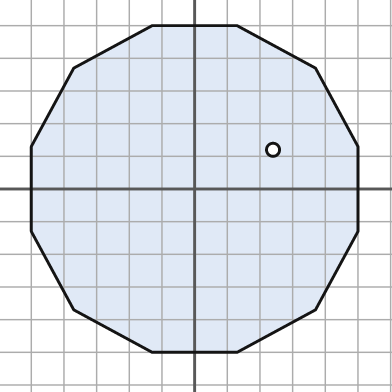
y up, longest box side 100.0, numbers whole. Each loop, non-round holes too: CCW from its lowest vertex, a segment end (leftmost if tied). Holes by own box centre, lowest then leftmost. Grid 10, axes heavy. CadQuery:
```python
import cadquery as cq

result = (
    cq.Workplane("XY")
    .moveTo(-13.0, -50.0)
    .lineTo(13.0, -50.0)
    .lineTo(37.0, -37.0)
    .lineTo(50.0, -13.0)
    .lineTo(50.0, 13.0)
    .lineTo(37.0, 37.0)
    .lineTo(13.0, 50.0)
    .lineTo(-13.0, 50.0)
    .lineTo(-37.0, 37.0)
    .lineTo(-50.0, 13.0)
    .lineTo(-50.0, -13.0)
    .lineTo(-37.0, -37.0)
    .close()
    .moveTo(24.0, 12.0)
    .circle(2.0)
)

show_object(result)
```